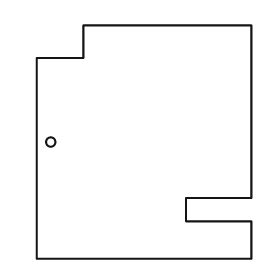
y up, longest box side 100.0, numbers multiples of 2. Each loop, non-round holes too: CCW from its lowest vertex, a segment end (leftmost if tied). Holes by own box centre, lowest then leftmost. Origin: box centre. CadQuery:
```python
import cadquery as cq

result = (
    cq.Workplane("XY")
    .moveTo(-46.0, -50.0)
    .lineTo(46.0, -50.0)
    .lineTo(46.0, -34.0)
    .lineTo(18.0, -34.0)
    .lineTo(18.0, -24.0)
    .lineTo(46.0, -24.0)
    .lineTo(46.0, 50.0)
    .lineTo(-26.0, 50.0)
    .lineTo(-26.0, 36.0)
    .lineTo(-46.0, 36.0)
    .close()
    .moveTo(-40.0, 0.0)
    .circle(2.0)
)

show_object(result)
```